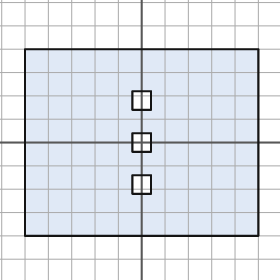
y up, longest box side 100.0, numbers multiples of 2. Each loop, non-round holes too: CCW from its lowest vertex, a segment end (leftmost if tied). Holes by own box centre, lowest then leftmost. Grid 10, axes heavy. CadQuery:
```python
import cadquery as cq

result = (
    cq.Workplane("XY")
    .moveTo(-50.0, -40.0)
    .lineTo(50.0, -40.0)
    .lineTo(50.0, 40.0)
    .lineTo(-50.0, 40.0)
    .close()
    .moveTo(-4.0, -22.0)
    .lineTo(4.0, -22.0)
    .lineTo(4.0, -14.0)
    .lineTo(-4.0, -14.0)
    .close()
    .moveTo(-4.0, -4.0)
    .lineTo(4.0, -4.0)
    .lineTo(4.0, 4.0)
    .lineTo(-4.0, 4.0)
    .close()
    .moveTo(-4.0, 14.0)
    .lineTo(4.0, 14.0)
    .lineTo(4.0, 22.0)
    .lineTo(-4.0, 22.0)
    .close()
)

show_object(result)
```